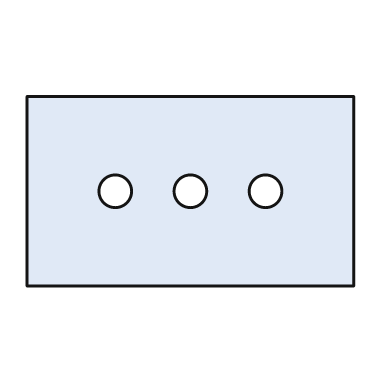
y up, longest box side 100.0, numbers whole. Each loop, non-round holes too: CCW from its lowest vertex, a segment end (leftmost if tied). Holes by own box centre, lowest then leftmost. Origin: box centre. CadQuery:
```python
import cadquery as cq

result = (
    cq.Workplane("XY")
    .moveTo(-50.0, -29.0)
    .lineTo(50.0, -29.0)
    .lineTo(50.0, 29.0)
    .lineTo(-50.0, 29.0)
    .close()
    .moveTo(-23.0, 0.0)
    .circle(5.0)
    .moveTo(0.0, 0.0)
    .circle(5.0)
    .moveTo(23.0, 0.0)
    .circle(5.0)
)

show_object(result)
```